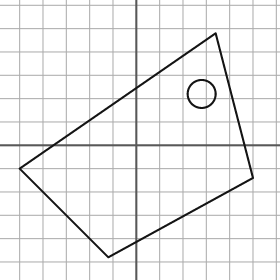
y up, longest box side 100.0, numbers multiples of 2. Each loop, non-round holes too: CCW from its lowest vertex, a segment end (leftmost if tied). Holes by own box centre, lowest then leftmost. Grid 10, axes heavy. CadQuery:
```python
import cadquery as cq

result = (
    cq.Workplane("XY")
    .moveTo(-12.0, -48.0)
    .lineTo(50.0, -14.0)
    .lineTo(34.0, 48.0)
    .lineTo(-50.0, -10.0)
    .close()
    .moveTo(28.0, 22.0)
    .circle(6.0)
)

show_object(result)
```